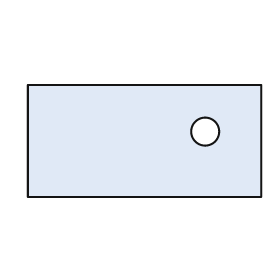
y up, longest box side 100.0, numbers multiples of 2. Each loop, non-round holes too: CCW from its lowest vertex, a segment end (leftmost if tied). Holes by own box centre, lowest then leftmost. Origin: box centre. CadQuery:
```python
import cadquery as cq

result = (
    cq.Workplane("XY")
    .moveTo(-50.0, -24.0)
    .lineTo(50.0, -24.0)
    .lineTo(50.0, 24.0)
    .lineTo(-50.0, 24.0)
    .close()
    .moveTo(26.0, 4.0)
    .circle(6.0)
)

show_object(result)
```